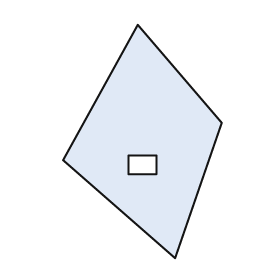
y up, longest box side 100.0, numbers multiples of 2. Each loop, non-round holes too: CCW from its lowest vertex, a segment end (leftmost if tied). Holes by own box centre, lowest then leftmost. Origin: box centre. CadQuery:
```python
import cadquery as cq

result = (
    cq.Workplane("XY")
    .moveTo(14.0, -50.0)
    .lineTo(34.0, 8.0)
    .lineTo(-2.0, 50.0)
    .lineTo(-34.0, -8.0)
    .close()
    .moveTo(-6.0, -14.0)
    .lineTo(6.0, -14.0)
    .lineTo(6.0, -6.0)
    .lineTo(-6.0, -6.0)
    .close()
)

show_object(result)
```